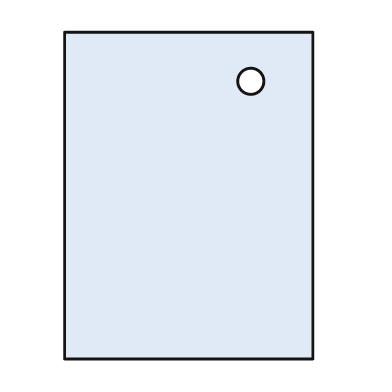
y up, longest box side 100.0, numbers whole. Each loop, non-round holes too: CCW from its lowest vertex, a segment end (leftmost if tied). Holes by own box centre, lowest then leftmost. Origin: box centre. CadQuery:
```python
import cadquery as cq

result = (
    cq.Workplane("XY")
    .moveTo(-38.0, -50.0)
    .lineTo(38.0, -50.0)
    .lineTo(38.0, 50.0)
    .lineTo(-38.0, 50.0)
    .close()
    .moveTo(19.0, 35.0)
    .circle(4.0)
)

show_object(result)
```